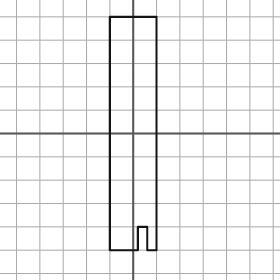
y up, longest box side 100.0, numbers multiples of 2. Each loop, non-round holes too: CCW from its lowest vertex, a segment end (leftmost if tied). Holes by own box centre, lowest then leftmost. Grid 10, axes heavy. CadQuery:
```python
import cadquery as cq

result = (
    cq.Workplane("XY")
    .moveTo(-10.0, -50.0)
    .lineTo(2.0, -50.0)
    .lineTo(2.0, -40.0)
    .lineTo(6.0, -40.0)
    .lineTo(6.0, -50.0)
    .lineTo(10.0, -50.0)
    .lineTo(10.0, 50.0)
    .lineTo(-10.0, 50.0)
    .close()
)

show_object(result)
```